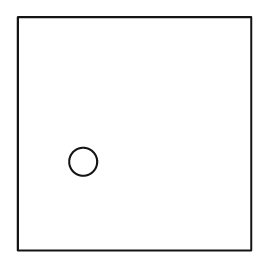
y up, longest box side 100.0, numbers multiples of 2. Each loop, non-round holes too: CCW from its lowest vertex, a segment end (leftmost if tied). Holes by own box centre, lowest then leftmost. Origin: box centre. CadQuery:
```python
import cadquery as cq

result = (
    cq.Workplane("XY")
    .moveTo(-50.0, -50.0)
    .lineTo(50.0, -50.0)
    .lineTo(50.0, 50.0)
    .lineTo(-50.0, 50.0)
    .close()
    .moveTo(-22.0, -12.0)
    .circle(6.0)
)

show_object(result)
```